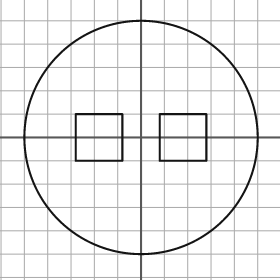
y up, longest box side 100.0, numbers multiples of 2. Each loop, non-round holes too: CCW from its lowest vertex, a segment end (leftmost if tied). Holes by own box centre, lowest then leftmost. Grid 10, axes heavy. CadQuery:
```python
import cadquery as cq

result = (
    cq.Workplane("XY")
    .moveTo(0.0, 0.0)
    .circle(50.0)
    .moveTo(-28.0, -10.0)
    .lineTo(-8.0, -10.0)
    .lineTo(-8.0, 10.0)
    .lineTo(-28.0, 10.0)
    .close()
    .moveTo(8.0, -10.0)
    .lineTo(28.0, -10.0)
    .lineTo(28.0, 10.0)
    .lineTo(8.0, 10.0)
    .close()
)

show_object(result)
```